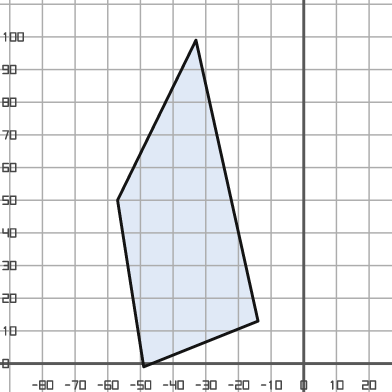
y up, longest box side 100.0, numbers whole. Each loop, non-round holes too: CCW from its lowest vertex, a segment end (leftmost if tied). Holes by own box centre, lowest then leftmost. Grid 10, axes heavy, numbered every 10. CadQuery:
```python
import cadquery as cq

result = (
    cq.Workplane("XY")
    .moveTo(-49.0, -1.0)
    .lineTo(-14.0, 13.0)
    .lineTo(-33.0, 99.0)
    .lineTo(-57.0, 50.0)
    .close()
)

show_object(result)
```